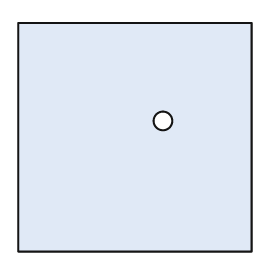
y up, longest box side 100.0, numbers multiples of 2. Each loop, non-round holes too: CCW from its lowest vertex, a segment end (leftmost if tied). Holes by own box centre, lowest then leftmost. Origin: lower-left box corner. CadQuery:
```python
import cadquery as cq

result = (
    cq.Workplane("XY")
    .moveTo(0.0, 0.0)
    .lineTo(100.0, 0.0)
    .lineTo(100.0, 98.0)
    .lineTo(0.0, 98.0)
    .close()
    .moveTo(62.0, 56.0)
    .circle(4.0)
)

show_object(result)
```